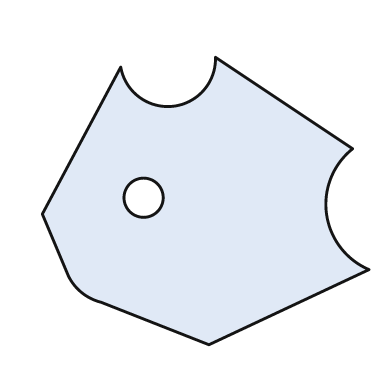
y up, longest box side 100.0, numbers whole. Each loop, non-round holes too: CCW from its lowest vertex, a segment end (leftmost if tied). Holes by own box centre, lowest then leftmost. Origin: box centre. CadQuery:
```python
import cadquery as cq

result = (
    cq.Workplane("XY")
    .moveTo(1.0, -44.0)
    .lineTo(50.0, -21.0)
    .threePointArc((37.0, -4.0), (45.0, 16.0))
    .lineTo(3.0, 44.0)
    .threePointArc((-10.0, 29.0), (-26.0, 41.0))
    .lineTo(-50.0, -4.0)
    .lineTo(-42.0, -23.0)
    .threePointArc((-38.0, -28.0), (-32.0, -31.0))
    .close()
    .moveTo(-19.0, 1.0)
    .circle(6.0)
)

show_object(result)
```